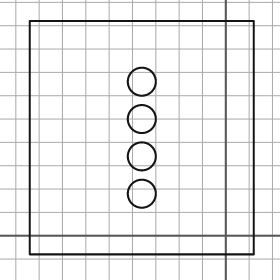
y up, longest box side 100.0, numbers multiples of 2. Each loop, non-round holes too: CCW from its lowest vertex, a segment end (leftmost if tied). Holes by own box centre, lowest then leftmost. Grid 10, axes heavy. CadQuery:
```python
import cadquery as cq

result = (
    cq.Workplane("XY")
    .moveTo(-84.0, -8.0)
    .lineTo(12.0, -8.0)
    .lineTo(12.0, 92.0)
    .lineTo(-84.0, 92.0)
    .close()
    .moveTo(-36.0, 18.0)
    .circle(6.0)
    .moveTo(-36.0, 34.0)
    .circle(6.0)
    .moveTo(-36.0, 50.0)
    .circle(6.0)
    .moveTo(-36.0, 66.0)
    .circle(6.0)
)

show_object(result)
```